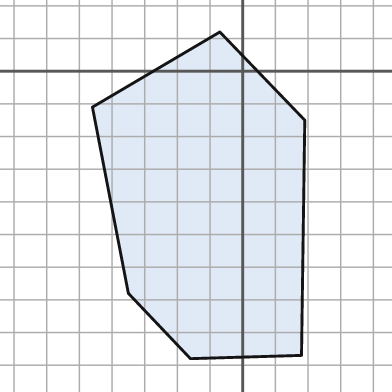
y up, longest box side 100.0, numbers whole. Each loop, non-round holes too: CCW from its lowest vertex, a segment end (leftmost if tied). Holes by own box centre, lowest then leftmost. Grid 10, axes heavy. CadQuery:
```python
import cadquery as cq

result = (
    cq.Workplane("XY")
    .moveTo(-16.0, -88.0)
    .lineTo(18.0, -87.0)
    .lineTo(19.0, -15.0)
    .lineTo(-7.0, 12.0)
    .lineTo(-46.0, -11.0)
    .lineTo(-35.0, -68.0)
    .close()
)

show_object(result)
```